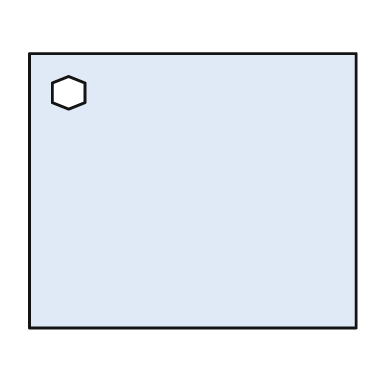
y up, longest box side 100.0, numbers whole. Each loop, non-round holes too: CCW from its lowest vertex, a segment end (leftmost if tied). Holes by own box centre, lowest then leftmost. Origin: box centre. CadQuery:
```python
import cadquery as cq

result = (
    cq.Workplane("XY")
    .moveTo(-50.0, -42.0)
    .lineTo(50.0, -42.0)
    .lineTo(50.0, 42.0)
    .lineTo(-50.0, 42.0)
    .close()
    .moveTo(-38.0, 25.0)
    .lineTo(-33.0, 27.0)
    .lineTo(-33.0, 33.0)
    .lineTo(-38.0, 35.0)
    .lineTo(-43.0, 33.0)
    .lineTo(-43.0, 27.0)
    .close()
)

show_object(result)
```